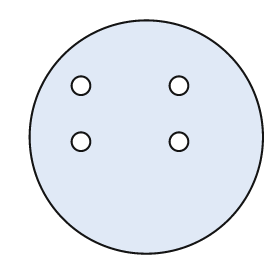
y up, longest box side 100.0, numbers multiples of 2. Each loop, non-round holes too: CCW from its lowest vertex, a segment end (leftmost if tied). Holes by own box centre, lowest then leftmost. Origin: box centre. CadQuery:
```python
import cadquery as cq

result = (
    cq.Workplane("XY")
    .moveTo(0.0, 0.0)
    .circle(50.0)
    .moveTo(-28.0, -2.0)
    .circle(4.0)
    .moveTo(14.0, -2.0)
    .circle(4.0)
    .moveTo(-28.0, 22.0)
    .circle(4.0)
    .moveTo(14.0, 22.0)
    .circle(4.0)
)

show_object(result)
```